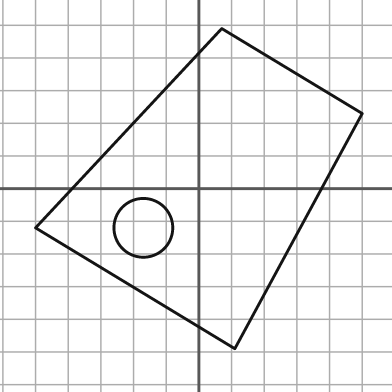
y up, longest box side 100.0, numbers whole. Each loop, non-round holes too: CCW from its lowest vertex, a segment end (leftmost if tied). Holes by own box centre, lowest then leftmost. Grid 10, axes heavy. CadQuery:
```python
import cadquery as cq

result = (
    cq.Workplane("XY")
    .moveTo(11.0, -49.0)
    .lineTo(50.0, 23.0)
    .lineTo(7.0, 49.0)
    .lineTo(-50.0, -12.0)
    .close()
    .moveTo(-17.0, -12.0)
    .circle(9.0)
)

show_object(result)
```